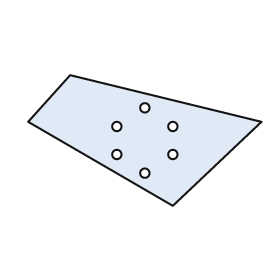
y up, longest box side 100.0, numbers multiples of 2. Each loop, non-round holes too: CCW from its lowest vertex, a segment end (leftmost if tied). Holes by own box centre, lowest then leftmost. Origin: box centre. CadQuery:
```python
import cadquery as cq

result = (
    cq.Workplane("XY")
    .moveTo(12.0, -28.0)
    .lineTo(50.0, 8.0)
    .lineTo(-32.0, 28.0)
    .lineTo(-50.0, 8.0)
    .close()
    .moveTo(0.0, -14.0)
    .circle(2.0)
    .moveTo(-12.0, -6.0)
    .circle(2.0)
    .moveTo(12.0, -6.0)
    .circle(2.0)
    .moveTo(-12.0, 6.0)
    .circle(2.0)
    .moveTo(12.0, 6.0)
    .circle(2.0)
    .moveTo(0.0, 14.0)
    .circle(2.0)
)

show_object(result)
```